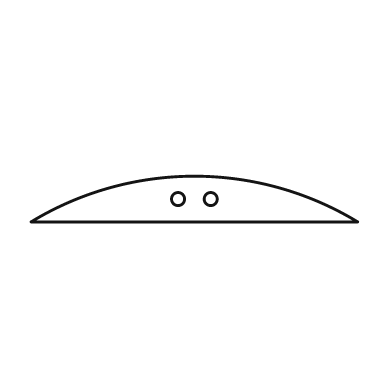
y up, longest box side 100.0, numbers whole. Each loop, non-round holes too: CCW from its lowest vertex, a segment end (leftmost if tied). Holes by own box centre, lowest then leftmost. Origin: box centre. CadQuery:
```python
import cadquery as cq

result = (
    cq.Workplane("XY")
    .moveTo(-50.0, -7.0)
    .lineTo(50.0, -7.0)
    .threePointArc((0.0, 7.0), (-50.0, -7.0))
    .close()
    .moveTo(-5.0, 0.0)
    .circle(2.0)
    .moveTo(5.0, 0.0)
    .circle(2.0)
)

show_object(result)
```